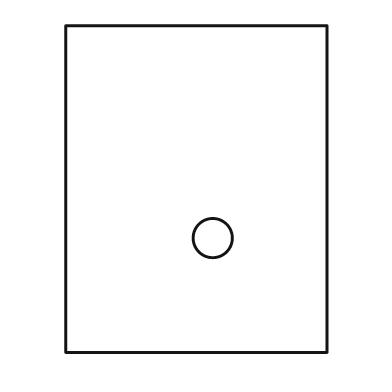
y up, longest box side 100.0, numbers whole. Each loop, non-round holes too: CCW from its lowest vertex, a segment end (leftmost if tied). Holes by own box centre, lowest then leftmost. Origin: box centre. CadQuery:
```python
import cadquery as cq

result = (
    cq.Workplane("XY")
    .moveTo(-40.0, -50.0)
    .lineTo(40.0, -50.0)
    .lineTo(40.0, 50.0)
    .lineTo(-40.0, 50.0)
    .close()
    .moveTo(5.0, -15.0)
    .circle(6.0)
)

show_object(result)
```